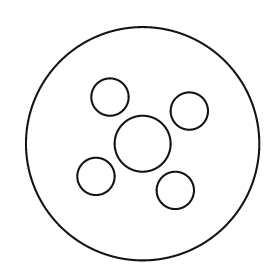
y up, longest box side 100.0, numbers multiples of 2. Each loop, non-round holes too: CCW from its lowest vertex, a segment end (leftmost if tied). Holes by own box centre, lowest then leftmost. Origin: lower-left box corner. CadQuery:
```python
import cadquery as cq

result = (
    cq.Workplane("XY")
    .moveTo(50.0, 50.0)
    .circle(50.0)
    .moveTo(64.0, 30.0)
    .circle(8.0)
    .moveTo(30.0, 36.0)
    .circle(8.0)
    .moveTo(50.0, 50.0)
    .circle(12.0)
    .moveTo(70.0, 64.0)
    .circle(8.0)
    .moveTo(36.0, 70.0)
    .circle(8.0)
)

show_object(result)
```